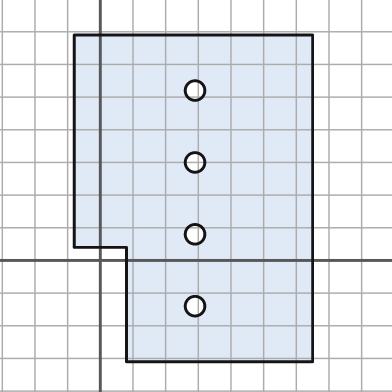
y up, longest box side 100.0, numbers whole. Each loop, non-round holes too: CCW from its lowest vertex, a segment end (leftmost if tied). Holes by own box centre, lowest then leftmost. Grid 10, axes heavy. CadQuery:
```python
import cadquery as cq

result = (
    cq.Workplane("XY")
    .moveTo(8.0, -31.0)
    .lineTo(65.0, -31.0)
    .lineTo(65.0, 69.0)
    .lineTo(-8.0, 69.0)
    .lineTo(-8.0, 4.0)
    .lineTo(8.0, 4.0)
    .close()
    .moveTo(29.0, -14.0)
    .circle(3.0)
    .moveTo(29.0, 8.0)
    .circle(3.0)
    .moveTo(29.0, 30.0)
    .circle(3.0)
    .moveTo(29.0, 52.0)
    .circle(3.0)
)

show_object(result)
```